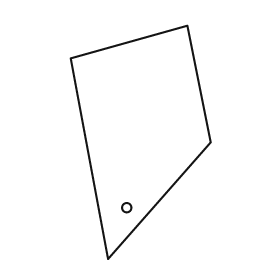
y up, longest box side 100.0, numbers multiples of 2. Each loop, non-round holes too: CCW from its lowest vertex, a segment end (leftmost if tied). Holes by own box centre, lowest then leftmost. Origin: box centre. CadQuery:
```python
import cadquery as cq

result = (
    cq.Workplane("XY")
    .moveTo(-14.0, -50.0)
    .lineTo(30.0, 0.0)
    .lineTo(20.0, 50.0)
    .lineTo(-30.0, 36.0)
    .close()
    .moveTo(-6.0, -28.0)
    .circle(2.0)
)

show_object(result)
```